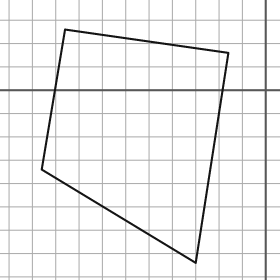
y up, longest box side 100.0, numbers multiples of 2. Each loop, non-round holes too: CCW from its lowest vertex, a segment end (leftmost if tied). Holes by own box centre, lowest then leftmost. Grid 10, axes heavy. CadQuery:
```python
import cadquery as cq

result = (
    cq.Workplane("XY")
    .moveTo(-30.0, -74.0)
    .lineTo(-16.0, 16.0)
    .lineTo(-86.0, 26.0)
    .lineTo(-96.0, -34.0)
    .close()
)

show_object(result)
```